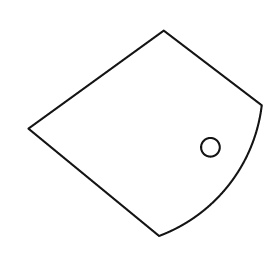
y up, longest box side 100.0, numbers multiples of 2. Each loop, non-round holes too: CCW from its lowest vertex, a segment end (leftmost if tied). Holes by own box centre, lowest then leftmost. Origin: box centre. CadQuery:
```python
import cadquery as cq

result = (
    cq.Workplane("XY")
    .moveTo(6.0, -44.0)
    .threePointArc((36.0, -22.0), (50.0, 12.0))
    .lineTo(8.0, 44.0)
    .lineTo(-50.0, 2.0)
    .close()
    .moveTo(28.0, -6.0)
    .circle(4.0)
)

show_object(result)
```